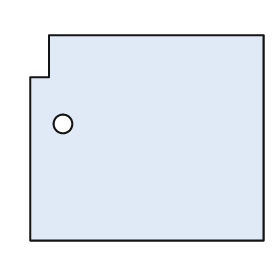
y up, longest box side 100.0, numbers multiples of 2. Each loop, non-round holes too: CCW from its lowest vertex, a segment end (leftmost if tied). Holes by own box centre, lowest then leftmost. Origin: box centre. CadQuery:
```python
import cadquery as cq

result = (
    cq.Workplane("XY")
    .moveTo(-50.0, -44.0)
    .lineTo(50.0, -44.0)
    .lineTo(50.0, 44.0)
    .lineTo(-42.0, 44.0)
    .lineTo(-42.0, 26.0)
    .lineTo(-50.0, 26.0)
    .close()
    .moveTo(-36.0, 6.0)
    .circle(4.0)
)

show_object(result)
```